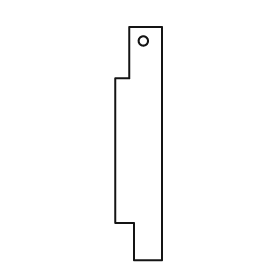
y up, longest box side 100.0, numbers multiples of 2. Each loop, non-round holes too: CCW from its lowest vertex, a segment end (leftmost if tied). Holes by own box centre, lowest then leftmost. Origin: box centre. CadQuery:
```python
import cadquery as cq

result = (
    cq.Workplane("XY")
    .moveTo(-2.0, -50.0)
    .lineTo(10.0, -50.0)
    .lineTo(10.0, 50.0)
    .lineTo(-4.0, 50.0)
    .lineTo(-4.0, 28.0)
    .lineTo(-10.0, 28.0)
    .lineTo(-10.0, -34.0)
    .lineTo(-2.0, -34.0)
    .close()
    .moveTo(2.0, 44.0)
    .circle(2.0)
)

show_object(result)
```